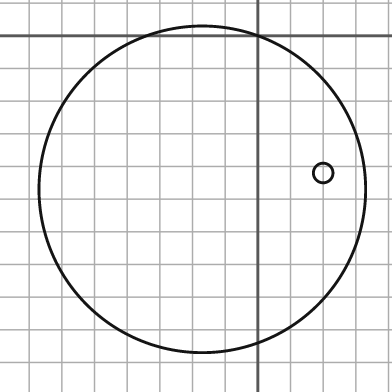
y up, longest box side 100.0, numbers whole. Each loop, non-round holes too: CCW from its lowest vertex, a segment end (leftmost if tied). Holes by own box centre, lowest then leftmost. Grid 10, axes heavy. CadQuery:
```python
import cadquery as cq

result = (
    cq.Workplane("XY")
    .moveTo(-17.0, -47.0)
    .circle(50.0)
    .moveTo(20.0, -42.0)
    .circle(3.0)
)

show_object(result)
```